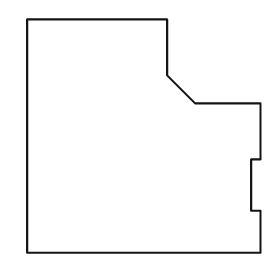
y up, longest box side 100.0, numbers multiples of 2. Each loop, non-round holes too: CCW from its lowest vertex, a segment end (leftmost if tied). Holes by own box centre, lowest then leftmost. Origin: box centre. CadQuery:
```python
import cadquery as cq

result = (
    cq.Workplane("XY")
    .moveTo(-50.0, -50.0)
    .lineTo(50.0, -50.0)
    .lineTo(50.0, -32.0)
    .lineTo(46.0, -32.0)
    .lineTo(46.0, -10.0)
    .lineTo(50.0, -10.0)
    .lineTo(50.0, 14.0)
    .lineTo(22.0, 14.0)
    .lineTo(10.0, 26.0)
    .lineTo(10.0, 50.0)
    .lineTo(-50.0, 50.0)
    .close()
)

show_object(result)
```